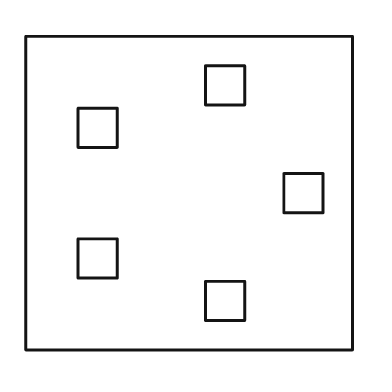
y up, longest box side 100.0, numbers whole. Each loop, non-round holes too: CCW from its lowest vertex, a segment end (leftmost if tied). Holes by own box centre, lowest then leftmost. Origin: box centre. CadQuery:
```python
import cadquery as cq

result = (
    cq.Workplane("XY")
    .moveTo(-50.0, -48.0)
    .lineTo(50.0, -48.0)
    .lineTo(50.0, 48.0)
    .lineTo(-50.0, 48.0)
    .close()
    .moveTo(5.0, -39.0)
    .lineTo(17.0, -39.0)
    .lineTo(17.0, -27.0)
    .lineTo(5.0, -27.0)
    .close()
    .moveTo(-34.0, -26.0)
    .lineTo(-22.0, -26.0)
    .lineTo(-22.0, -14.0)
    .lineTo(-34.0, -14.0)
    .close()
    .moveTo(29.0, -6.0)
    .lineTo(41.0, -6.0)
    .lineTo(41.0, 6.0)
    .lineTo(29.0, 6.0)
    .close()
    .moveTo(-34.0, 14.0)
    .lineTo(-22.0, 14.0)
    .lineTo(-22.0, 26.0)
    .lineTo(-34.0, 26.0)
    .close()
    .moveTo(5.0, 27.0)
    .lineTo(17.0, 27.0)
    .lineTo(17.0, 39.0)
    .lineTo(5.0, 39.0)
    .close()
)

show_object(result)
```